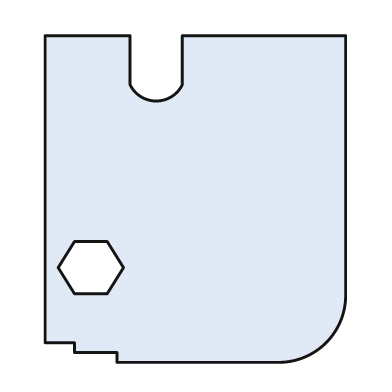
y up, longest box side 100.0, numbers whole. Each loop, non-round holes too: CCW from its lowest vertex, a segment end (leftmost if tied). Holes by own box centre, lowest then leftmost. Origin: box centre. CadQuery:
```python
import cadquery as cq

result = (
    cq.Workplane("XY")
    .moveTo(-24.0, -50.0)
    .lineTo(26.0, -50.0)
    .threePointArc((40.0, -44.0), (46.0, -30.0))
    .lineTo(46.0, 50.0)
    .lineTo(-4.0, 50.0)
    .lineTo(-4.0, 35.0)
    .threePointArc((-12.0, 30.0), (-20.0, 35.0))
    .lineTo(-20.0, 50.0)
    .lineTo(-46.0, 50.0)
    .lineTo(-46.0, -44.0)
    .lineTo(-37.0, -44.0)
    .lineTo(-37.0, -47.0)
    .lineTo(-24.0, -47.0)
    .close()
    .moveTo(-37.0, -29.0)
    .lineTo(-27.0, -29.0)
    .lineTo(-22.0, -21.0)
    .lineTo(-27.0, -13.0)
    .lineTo(-37.0, -13.0)
    .lineTo(-42.0, -21.0)
    .close()
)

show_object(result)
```